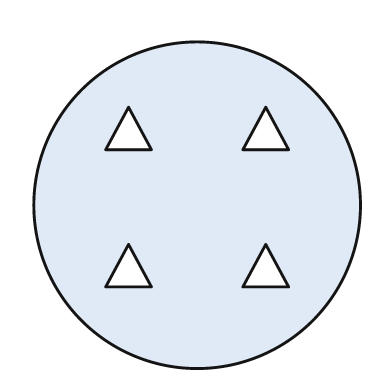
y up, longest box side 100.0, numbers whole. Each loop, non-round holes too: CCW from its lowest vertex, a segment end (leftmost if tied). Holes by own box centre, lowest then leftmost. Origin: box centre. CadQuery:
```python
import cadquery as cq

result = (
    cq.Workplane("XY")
    .moveTo(0.0, 0.0)
    .circle(50.0)
    .moveTo(-28.0, -25.0)
    .lineTo(-14.0, -25.0)
    .lineTo(-21.0, -12.0)
    .close()
    .moveTo(14.0, -25.0)
    .lineTo(28.0, -25.0)
    .lineTo(21.0, -12.0)
    .close()
    .moveTo(-28.0, 17.0)
    .lineTo(-14.0, 17.0)
    .lineTo(-21.0, 30.0)
    .close()
    .moveTo(14.0, 17.0)
    .lineTo(28.0, 17.0)
    .lineTo(21.0, 30.0)
    .close()
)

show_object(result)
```